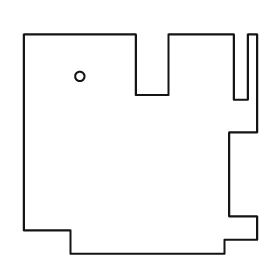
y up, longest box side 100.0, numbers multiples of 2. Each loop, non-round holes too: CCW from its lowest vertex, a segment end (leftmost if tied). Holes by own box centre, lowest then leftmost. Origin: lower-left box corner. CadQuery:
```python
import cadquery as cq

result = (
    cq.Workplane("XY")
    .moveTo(20.0, 0.0)
    .lineTo(86.0, 0.0)
    .lineTo(86.0, 6.0)
    .lineTo(100.0, 6.0)
    .lineTo(100.0, 16.0)
    .lineTo(88.0, 16.0)
    .lineTo(88.0, 52.0)
    .lineTo(100.0, 52.0)
    .lineTo(100.0, 94.0)
    .lineTo(96.0, 94.0)
    .lineTo(96.0, 66.0)
    .lineTo(90.0, 66.0)
    .lineTo(90.0, 94.0)
    .lineTo(62.0, 94.0)
    .lineTo(62.0, 68.0)
    .lineTo(48.0, 68.0)
    .lineTo(48.0, 94.0)
    .lineTo(0.0, 94.0)
    .lineTo(0.0, 10.0)
    .lineTo(20.0, 10.0)
    .close()
    .moveTo(24.0, 76.0)
    .circle(2.0)
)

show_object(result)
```